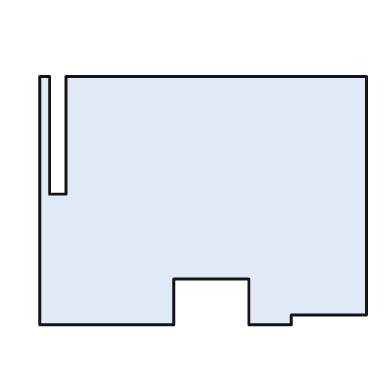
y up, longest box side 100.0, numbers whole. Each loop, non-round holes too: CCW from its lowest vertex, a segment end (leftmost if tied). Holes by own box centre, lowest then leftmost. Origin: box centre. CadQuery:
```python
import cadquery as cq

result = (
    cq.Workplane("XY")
    .moveTo(-50.0, -38.0)
    .lineTo(-9.0, -38.0)
    .lineTo(-9.0, -24.0)
    .lineTo(14.0, -24.0)
    .lineTo(14.0, -38.0)
    .lineTo(27.0, -38.0)
    .lineTo(27.0, -35.0)
    .lineTo(50.0, -35.0)
    .lineTo(50.0, 38.0)
    .lineTo(-42.0, 38.0)
    .lineTo(-42.0, 2.0)
    .lineTo(-47.0, 2.0)
    .lineTo(-47.0, 38.0)
    .lineTo(-50.0, 38.0)
    .close()
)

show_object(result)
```